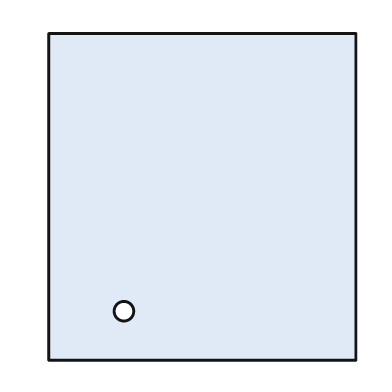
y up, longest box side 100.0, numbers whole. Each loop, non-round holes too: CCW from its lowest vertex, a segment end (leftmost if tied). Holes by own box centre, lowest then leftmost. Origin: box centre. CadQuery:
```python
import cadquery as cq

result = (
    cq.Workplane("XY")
    .moveTo(-47.0, -50.0)
    .lineTo(47.0, -50.0)
    .lineTo(47.0, 50.0)
    .lineTo(-47.0, 50.0)
    .close()
    .moveTo(-24.0, -35.0)
    .circle(3.0)
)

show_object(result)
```